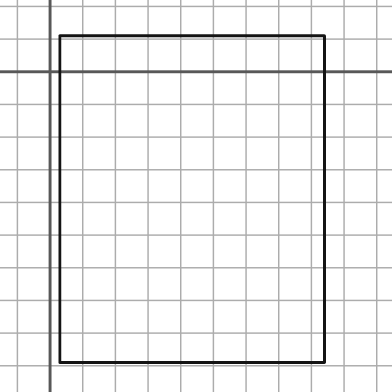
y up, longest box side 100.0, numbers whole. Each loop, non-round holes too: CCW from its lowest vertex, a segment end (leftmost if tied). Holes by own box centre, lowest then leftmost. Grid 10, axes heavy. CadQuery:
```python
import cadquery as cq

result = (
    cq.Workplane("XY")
    .moveTo(3.0, -89.0)
    .lineTo(84.0, -89.0)
    .lineTo(84.0, 11.0)
    .lineTo(3.0, 11.0)
    .close()
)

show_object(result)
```